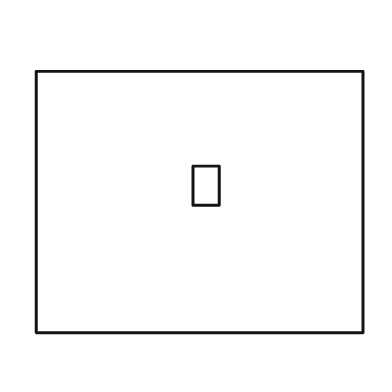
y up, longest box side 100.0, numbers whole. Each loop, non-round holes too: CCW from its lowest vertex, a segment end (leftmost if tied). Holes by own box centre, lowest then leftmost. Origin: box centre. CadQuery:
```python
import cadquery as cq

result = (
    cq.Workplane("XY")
    .moveTo(-50.0, -40.0)
    .lineTo(50.0, -40.0)
    .lineTo(50.0, 40.0)
    .lineTo(-50.0, 40.0)
    .close()
    .moveTo(-2.0, -1.0)
    .lineTo(6.0, -1.0)
    .lineTo(6.0, 11.0)
    .lineTo(-2.0, 11.0)
    .close()
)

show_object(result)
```